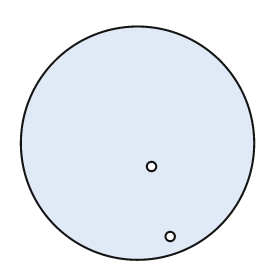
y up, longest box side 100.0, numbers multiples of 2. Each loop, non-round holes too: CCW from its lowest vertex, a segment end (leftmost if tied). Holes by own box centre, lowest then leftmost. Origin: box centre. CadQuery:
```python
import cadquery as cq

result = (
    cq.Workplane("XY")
    .moveTo(0.0, 0.0)
    .circle(50.0)
    .moveTo(14.0, -40.0)
    .circle(2.0)
    .moveTo(6.0, -10.0)
    .circle(2.0)
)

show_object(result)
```